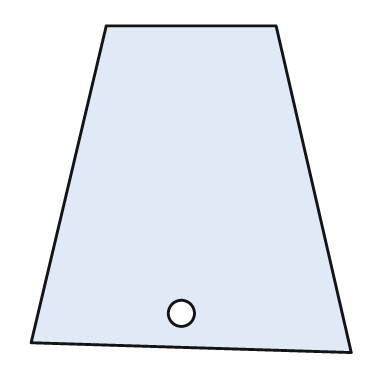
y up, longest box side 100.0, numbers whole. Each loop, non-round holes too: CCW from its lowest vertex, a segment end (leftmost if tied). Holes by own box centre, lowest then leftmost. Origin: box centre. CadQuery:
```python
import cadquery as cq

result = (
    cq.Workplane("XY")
    .moveTo(49.0, -50.0)
    .lineTo(26.0, 50.0)
    .lineTo(-26.0, 50.0)
    .lineTo(-49.0, -47.0)
    .close()
    .moveTo(-3.0, -38.0)
    .circle(4.0)
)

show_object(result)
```